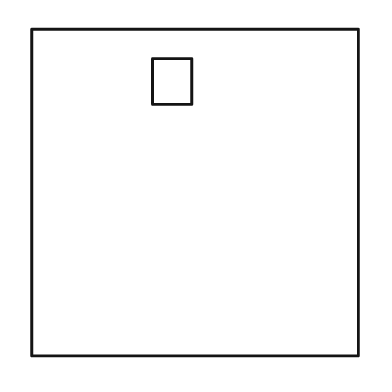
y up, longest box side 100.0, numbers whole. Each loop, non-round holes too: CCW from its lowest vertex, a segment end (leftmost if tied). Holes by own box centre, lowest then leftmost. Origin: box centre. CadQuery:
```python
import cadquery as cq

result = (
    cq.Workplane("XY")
    .moveTo(-50.0, -50.0)
    .lineTo(50.0, -50.0)
    .lineTo(50.0, 50.0)
    .lineTo(-50.0, 50.0)
    .close()
    .moveTo(-13.0, 27.0)
    .lineTo(-1.0, 27.0)
    .lineTo(-1.0, 41.0)
    .lineTo(-13.0, 41.0)
    .close()
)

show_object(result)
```